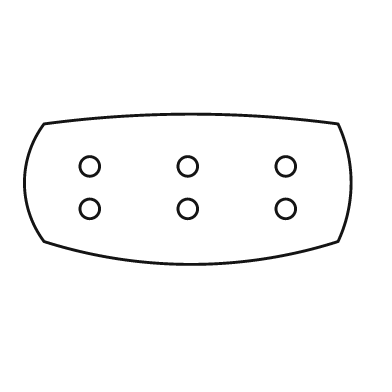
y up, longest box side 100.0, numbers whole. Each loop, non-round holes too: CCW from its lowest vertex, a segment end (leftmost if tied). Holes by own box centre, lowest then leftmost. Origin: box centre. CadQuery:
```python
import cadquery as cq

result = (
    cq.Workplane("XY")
    .moveTo(-44.0, -16.0)
    .threePointArc((1.0, -23.0), (46.0, -16.0))
    .threePointArc((50.0, 2.0), (46.0, 20.0))
    .threePointArc((1.0, 23.0), (-44.0, 20.0))
    .threePointArc((-50.0, 2.0), (-44.0, -16.0))
    .close()
    .moveTo(-30.0, -6.0)
    .circle(3.0)
    .moveTo(0.0, -6.0)
    .circle(3.0)
    .moveTo(30.0, -6.0)
    .circle(3.0)
    .moveTo(-30.0, 7.0)
    .circle(3.0)
    .moveTo(0.0, 7.0)
    .circle(3.0)
    .moveTo(30.0, 7.0)
    .circle(3.0)
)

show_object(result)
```